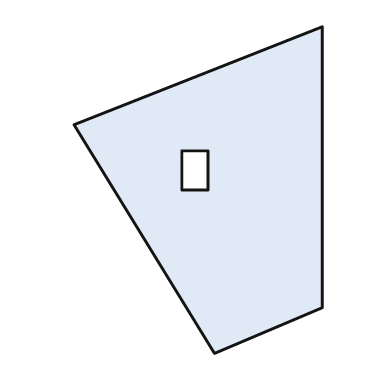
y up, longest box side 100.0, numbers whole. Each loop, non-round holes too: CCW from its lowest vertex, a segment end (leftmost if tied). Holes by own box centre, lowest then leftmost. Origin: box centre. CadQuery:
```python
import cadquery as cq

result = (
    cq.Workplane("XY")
    .moveTo(5.0, -50.0)
    .lineTo(38.0, -36.0)
    .lineTo(38.0, 50.0)
    .lineTo(-38.0, 20.0)
    .close()
    .moveTo(-5.0, 0.0)
    .lineTo(3.0, 0.0)
    .lineTo(3.0, 12.0)
    .lineTo(-5.0, 12.0)
    .close()
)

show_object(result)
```